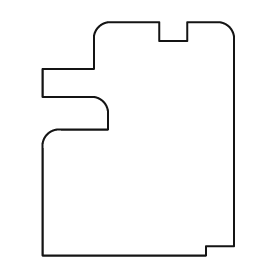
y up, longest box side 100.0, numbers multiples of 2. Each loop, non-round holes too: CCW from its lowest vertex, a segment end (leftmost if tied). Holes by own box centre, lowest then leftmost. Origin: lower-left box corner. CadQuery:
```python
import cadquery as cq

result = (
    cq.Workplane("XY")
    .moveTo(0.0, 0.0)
    .lineTo(70.0, 0.0)
    .lineTo(70.0, 4.0)
    .lineTo(82.0, 4.0)
    .lineTo(82.0, 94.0)
    .threePointArc((80.0, 98.0), (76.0, 100.0))
    .lineTo(62.0, 100.0)
    .lineTo(62.0, 92.0)
    .lineTo(50.0, 92.0)
    .lineTo(50.0, 100.0)
    .lineTo(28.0, 100.0)
    .threePointArc((24.0, 98.0), (22.0, 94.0))
    .lineTo(22.0, 80.0)
    .lineTo(0.0, 80.0)
    .lineTo(0.0, 68.0)
    .lineTo(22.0, 68.0)
    .threePointArc((26.0, 66.0), (28.0, 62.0))
    .lineTo(28.0, 54.0)
    .lineTo(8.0, 54.0)
    .threePointArc((2.0, 52.0), (0.0, 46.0))
    .close()
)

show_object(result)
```